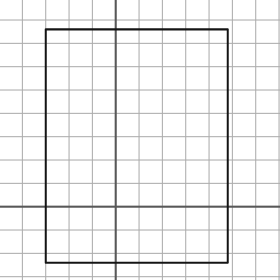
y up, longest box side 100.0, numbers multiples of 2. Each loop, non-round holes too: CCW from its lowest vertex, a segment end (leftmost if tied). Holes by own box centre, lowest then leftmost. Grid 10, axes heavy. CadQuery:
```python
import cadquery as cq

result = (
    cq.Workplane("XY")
    .moveTo(-30.0, -24.0)
    .lineTo(48.0, -24.0)
    .lineTo(48.0, 76.0)
    .lineTo(-30.0, 76.0)
    .close()
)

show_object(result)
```